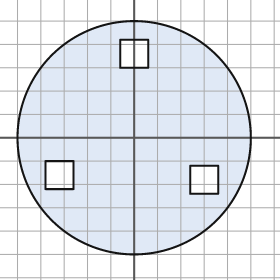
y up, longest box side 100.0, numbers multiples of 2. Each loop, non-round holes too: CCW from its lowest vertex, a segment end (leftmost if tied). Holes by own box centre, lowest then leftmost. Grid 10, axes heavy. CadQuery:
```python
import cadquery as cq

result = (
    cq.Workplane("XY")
    .moveTo(0.0, 0.0)
    .circle(50.0)
    .moveTo(24.0, -24.0)
    .lineTo(36.0, -24.0)
    .lineTo(36.0, -12.0)
    .lineTo(24.0, -12.0)
    .close()
    .moveTo(-38.0, -22.0)
    .lineTo(-26.0, -22.0)
    .lineTo(-26.0, -10.0)
    .lineTo(-38.0, -10.0)
    .close()
    .moveTo(-6.0, 30.0)
    .lineTo(6.0, 30.0)
    .lineTo(6.0, 42.0)
    .lineTo(-6.0, 42.0)
    .close()
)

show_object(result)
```